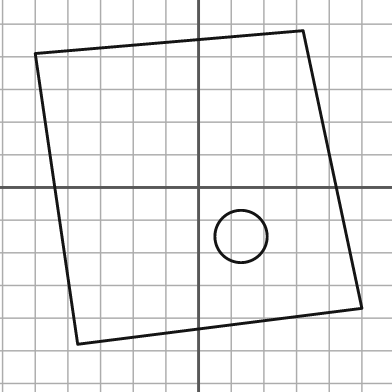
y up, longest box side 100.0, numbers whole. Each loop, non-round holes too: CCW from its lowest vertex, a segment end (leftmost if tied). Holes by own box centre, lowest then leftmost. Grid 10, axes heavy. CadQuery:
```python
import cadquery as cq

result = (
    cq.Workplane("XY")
    .moveTo(-37.0, -48.0)
    .lineTo(50.0, -37.0)
    .lineTo(32.0, 48.0)
    .lineTo(-50.0, 41.0)
    .close()
    .moveTo(13.0, -15.0)
    .circle(8.0)
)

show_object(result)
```